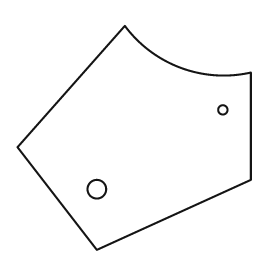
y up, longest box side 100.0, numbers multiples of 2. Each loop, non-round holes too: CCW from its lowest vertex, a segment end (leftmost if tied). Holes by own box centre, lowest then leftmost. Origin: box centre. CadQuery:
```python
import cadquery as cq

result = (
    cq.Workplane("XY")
    .moveTo(-16.0, -48.0)
    .lineTo(50.0, -18.0)
    .lineTo(50.0, 28.0)
    .threePointArc((20.0, 30.0), (-4.0, 48.0))
    .lineTo(-50.0, -4.0)
    .close()
    .moveTo(-16.0, -22.0)
    .circle(4.0)
    .moveTo(38.0, 12.0)
    .circle(2.0)
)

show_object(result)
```